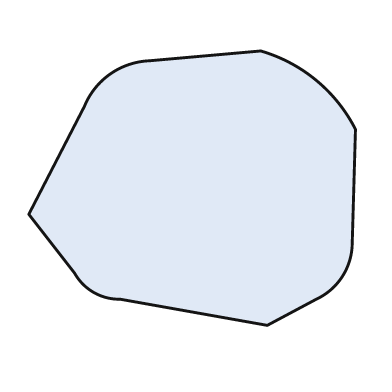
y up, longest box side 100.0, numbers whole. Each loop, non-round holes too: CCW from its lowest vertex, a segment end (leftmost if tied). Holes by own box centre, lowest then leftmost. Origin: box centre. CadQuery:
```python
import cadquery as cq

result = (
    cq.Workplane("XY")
    .moveTo(23.0, -42.0)
    .lineTo(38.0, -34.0)
    .threePointArc((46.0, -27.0), (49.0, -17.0))
    .lineTo(50.0, 18.0)
    .threePointArc((38.0, 33.0), (21.0, 42.0))
    .lineTo(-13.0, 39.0)
    .threePointArc((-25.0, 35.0), (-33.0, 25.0))
    .lineTo(-50.0, -8.0)
    .lineTo(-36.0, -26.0)
    .threePointArc((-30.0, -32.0), (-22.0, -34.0))
    .close()
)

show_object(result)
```